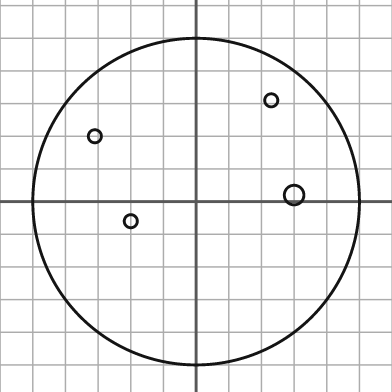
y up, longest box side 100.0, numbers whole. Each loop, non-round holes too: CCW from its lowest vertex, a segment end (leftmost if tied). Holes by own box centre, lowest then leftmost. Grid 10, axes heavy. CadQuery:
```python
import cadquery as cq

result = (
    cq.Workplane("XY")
    .moveTo(0.0, 0.0)
    .circle(50.0)
    .moveTo(-20.0, -6.0)
    .circle(2.0)
    .moveTo(30.0, 2.0)
    .circle(3.0)
    .moveTo(-31.0, 20.0)
    .circle(2.0)
    .moveTo(23.0, 31.0)
    .circle(2.0)
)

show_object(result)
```